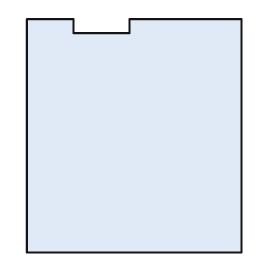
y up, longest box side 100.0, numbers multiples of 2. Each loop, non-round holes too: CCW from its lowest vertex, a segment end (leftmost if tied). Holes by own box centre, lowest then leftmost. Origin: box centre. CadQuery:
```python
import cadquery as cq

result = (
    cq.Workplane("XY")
    .moveTo(-46.0, -50.0)
    .lineTo(46.0, -50.0)
    .lineTo(46.0, 50.0)
    .lineTo(-2.0, 50.0)
    .lineTo(-2.0, 44.0)
    .lineTo(-26.0, 44.0)
    .lineTo(-26.0, 50.0)
    .lineTo(-46.0, 50.0)
    .close()
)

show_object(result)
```